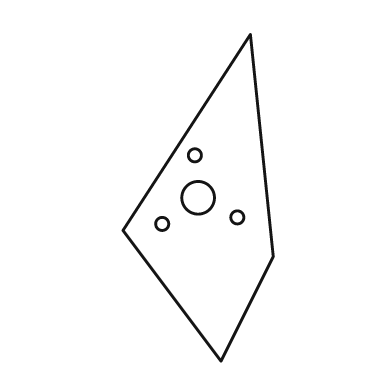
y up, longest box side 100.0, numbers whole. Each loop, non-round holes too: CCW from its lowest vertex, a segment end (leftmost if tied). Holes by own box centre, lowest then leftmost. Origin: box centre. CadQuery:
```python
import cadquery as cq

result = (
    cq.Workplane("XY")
    .moveTo(7.0, -50.0)
    .lineTo(23.0, -18.0)
    .lineTo(16.0, 50.0)
    .lineTo(-23.0, -10.0)
    .close()
    .moveTo(-11.0, -8.0)
    .circle(2.0)
    .moveTo(12.0, -6.0)
    .circle(2.0)
    .moveTo(0.0, 0.0)
    .circle(5.0)
    .moveTo(-1.0, 13.0)
    .circle(2.0)
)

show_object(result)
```